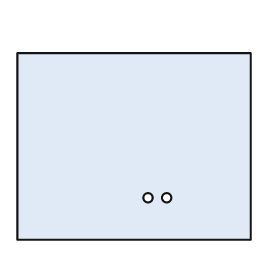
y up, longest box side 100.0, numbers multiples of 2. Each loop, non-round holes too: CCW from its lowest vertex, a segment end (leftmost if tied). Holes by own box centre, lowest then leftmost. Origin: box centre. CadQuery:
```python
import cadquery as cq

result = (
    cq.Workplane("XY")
    .moveTo(-50.0, -40.0)
    .lineTo(50.0, -40.0)
    .lineTo(50.0, 40.0)
    .lineTo(-50.0, 40.0)
    .close()
    .moveTo(6.0, -22.0)
    .circle(2.0)
    .moveTo(14.0, -22.0)
    .circle(2.0)
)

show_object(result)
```